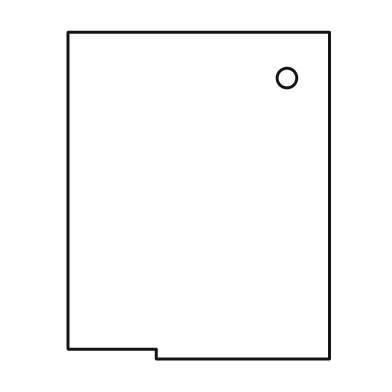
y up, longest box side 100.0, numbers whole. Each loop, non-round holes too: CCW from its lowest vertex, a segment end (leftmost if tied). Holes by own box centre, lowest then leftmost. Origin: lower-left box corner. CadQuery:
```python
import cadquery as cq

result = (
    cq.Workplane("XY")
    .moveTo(27.0, 0.0)
    .lineTo(80.0, 0.0)
    .lineTo(80.0, 100.0)
    .lineTo(0.0, 100.0)
    .lineTo(0.0, 3.0)
    .lineTo(27.0, 3.0)
    .close()
    .moveTo(67.0, 86.0)
    .circle(3.0)
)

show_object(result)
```